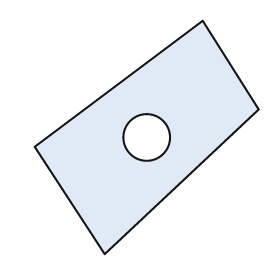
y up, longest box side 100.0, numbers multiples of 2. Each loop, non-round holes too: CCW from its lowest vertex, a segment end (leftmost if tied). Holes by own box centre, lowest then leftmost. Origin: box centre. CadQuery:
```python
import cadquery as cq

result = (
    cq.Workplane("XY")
    .moveTo(-18.0, -50.0)
    .lineTo(48.0, 12.0)
    .lineTo(24.0, 50.0)
    .lineTo(-48.0, -4.0)
    .close()
    .moveTo(0.0, 0.0)
    .circle(10.0)
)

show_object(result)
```